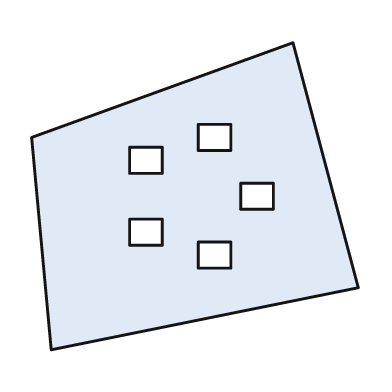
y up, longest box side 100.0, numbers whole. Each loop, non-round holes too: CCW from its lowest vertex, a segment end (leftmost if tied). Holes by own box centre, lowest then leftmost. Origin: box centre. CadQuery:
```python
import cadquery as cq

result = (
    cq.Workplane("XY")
    .moveTo(-44.0, -47.0)
    .lineTo(50.0, -28.0)
    .lineTo(30.0, 47.0)
    .lineTo(-50.0, 18.0)
    .close()
    .moveTo(1.0, -22.0)
    .lineTo(11.0, -22.0)
    .lineTo(11.0, -14.0)
    .lineTo(1.0, -14.0)
    .close()
    .moveTo(-20.0, -15.0)
    .lineTo(-10.0, -15.0)
    .lineTo(-10.0, -7.0)
    .lineTo(-20.0, -7.0)
    .close()
    .moveTo(14.0, -4.0)
    .lineTo(24.0, -4.0)
    .lineTo(24.0, 4.0)
    .lineTo(14.0, 4.0)
    .close()
    .moveTo(-20.0, 7.0)
    .lineTo(-10.0, 7.0)
    .lineTo(-10.0, 15.0)
    .lineTo(-20.0, 15.0)
    .close()
    .moveTo(1.0, 14.0)
    .lineTo(11.0, 14.0)
    .lineTo(11.0, 22.0)
    .lineTo(1.0, 22.0)
    .close()
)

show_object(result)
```